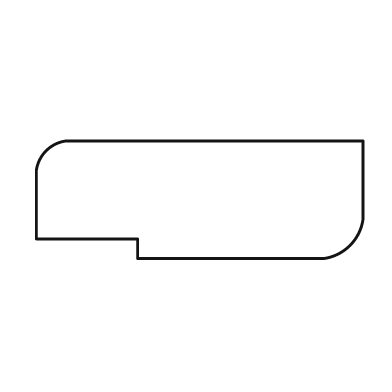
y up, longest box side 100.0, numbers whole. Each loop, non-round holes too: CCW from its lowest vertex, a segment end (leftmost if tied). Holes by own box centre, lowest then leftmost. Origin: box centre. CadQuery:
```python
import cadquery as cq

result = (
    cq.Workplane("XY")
    .moveTo(-19.0, -18.0)
    .lineTo(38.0, -18.0)
    .threePointArc((46.0, -14.0), (50.0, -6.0))
    .lineTo(50.0, 18.0)
    .lineTo(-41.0, 18.0)
    .threePointArc((-47.0, 15.0), (-50.0, 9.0))
    .lineTo(-50.0, -12.0)
    .lineTo(-19.0, -12.0)
    .close()
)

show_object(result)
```